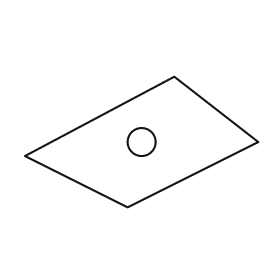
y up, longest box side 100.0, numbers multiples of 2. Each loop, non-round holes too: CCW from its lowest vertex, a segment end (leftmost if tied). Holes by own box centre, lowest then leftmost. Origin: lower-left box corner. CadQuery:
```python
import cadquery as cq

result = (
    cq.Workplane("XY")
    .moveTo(44.0, 0.0)
    .lineTo(100.0, 28.0)
    .lineTo(64.0, 56.0)
    .lineTo(0.0, 22.0)
    .close()
    .moveTo(50.0, 28.0)
    .circle(6.0)
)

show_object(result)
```